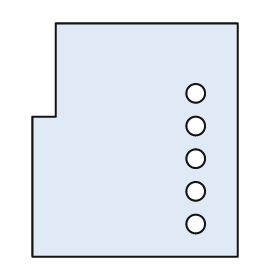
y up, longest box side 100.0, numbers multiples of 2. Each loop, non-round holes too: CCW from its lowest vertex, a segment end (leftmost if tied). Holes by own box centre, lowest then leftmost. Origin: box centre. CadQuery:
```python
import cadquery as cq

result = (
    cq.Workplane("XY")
    .moveTo(-44.0, -50.0)
    .lineTo(44.0, -50.0)
    .lineTo(44.0, 50.0)
    .lineTo(-34.0, 50.0)
    .lineTo(-34.0, 10.0)
    .lineTo(-44.0, 10.0)
    .close()
    .moveTo(26.0, -36.0)
    .circle(4.0)
    .moveTo(26.0, -22.0)
    .circle(4.0)
    .moveTo(26.0, -8.0)
    .circle(4.0)
    .moveTo(26.0, 6.0)
    .circle(4.0)
    .moveTo(26.0, 20.0)
    .circle(4.0)
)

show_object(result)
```